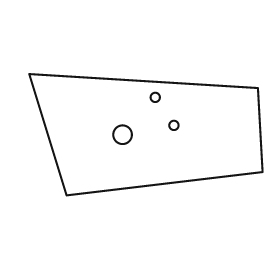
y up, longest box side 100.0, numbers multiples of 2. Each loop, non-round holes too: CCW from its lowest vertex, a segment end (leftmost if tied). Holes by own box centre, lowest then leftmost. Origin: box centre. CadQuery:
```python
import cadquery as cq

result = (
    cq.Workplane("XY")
    .moveTo(-34.0, -26.0)
    .lineTo(50.0, -16.0)
    .lineTo(48.0, 20.0)
    .lineTo(-50.0, 26.0)
    .close()
    .moveTo(-10.0, 0.0)
    .circle(4.0)
    .moveTo(12.0, 4.0)
    .circle(2.0)
    .moveTo(4.0, 16.0)
    .circle(2.0)
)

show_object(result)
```